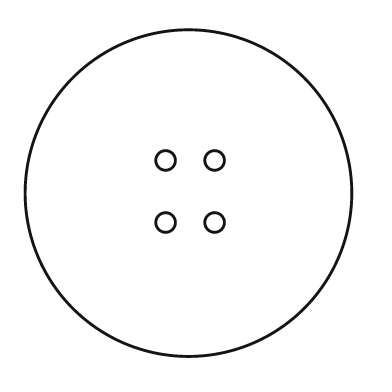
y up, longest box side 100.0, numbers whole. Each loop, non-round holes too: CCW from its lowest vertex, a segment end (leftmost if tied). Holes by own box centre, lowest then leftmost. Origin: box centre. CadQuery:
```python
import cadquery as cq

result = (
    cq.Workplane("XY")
    .moveTo(0.0, 0.0)
    .circle(50.0)
    .moveTo(-7.0, -9.0)
    .circle(3.0)
    .moveTo(8.0, -9.0)
    .circle(3.0)
    .moveTo(-7.0, 10.0)
    .circle(3.0)
    .moveTo(8.0, 10.0)
    .circle(3.0)
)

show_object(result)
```